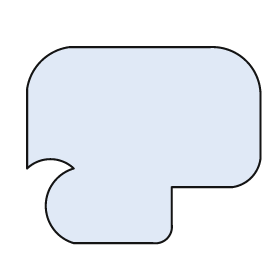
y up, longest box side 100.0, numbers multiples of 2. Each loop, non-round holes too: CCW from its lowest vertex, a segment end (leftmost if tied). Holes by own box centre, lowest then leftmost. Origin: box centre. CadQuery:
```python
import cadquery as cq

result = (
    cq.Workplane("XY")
    .moveTo(-30.0, -42.0)
    .lineTo(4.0, -42.0)
    .threePointArc((10.0, -40.0), (12.0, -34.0))
    .lineTo(12.0, -18.0)
    .lineTo(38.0, -18.0)
    .threePointArc((46.0, -14.0), (50.0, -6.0))
    .lineTo(50.0, 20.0)
    .threePointArc((44.0, 36.0), (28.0, 42.0))
    .lineTo(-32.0, 42.0)
    .threePointArc((-44.0, 36.0), (-50.0, 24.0))
    .lineTo(-50.0, -10.0)
    .threePointArc((-40.0, -6.0), (-30.0, -10.0))
    .threePointArc((-42.0, -26.0), (-30.0, -42.0))
    .close()
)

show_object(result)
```